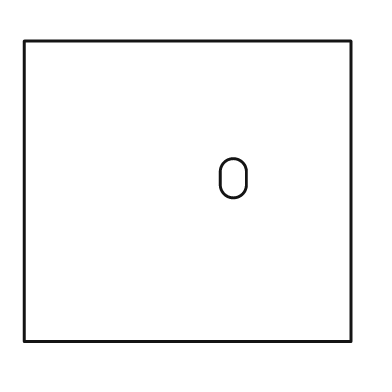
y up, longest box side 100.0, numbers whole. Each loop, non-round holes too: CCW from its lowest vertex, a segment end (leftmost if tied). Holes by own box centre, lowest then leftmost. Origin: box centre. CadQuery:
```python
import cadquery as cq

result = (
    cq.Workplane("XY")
    .moveTo(-50.0, -46.0)
    .lineTo(50.0, -46.0)
    .lineTo(50.0, 46.0)
    .lineTo(-50.0, 46.0)
    .close()
    .moveTo(10.0, 2.0)
    .threePointArc((14.0, -2.0), (18.0, 2.0))
    .lineTo(18.0, 6.0)
    .threePointArc((14.0, 10.0), (10.0, 6.0))
    .close()
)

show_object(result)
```